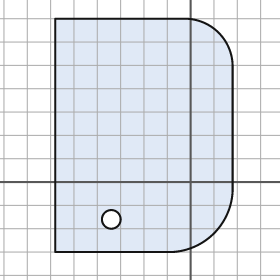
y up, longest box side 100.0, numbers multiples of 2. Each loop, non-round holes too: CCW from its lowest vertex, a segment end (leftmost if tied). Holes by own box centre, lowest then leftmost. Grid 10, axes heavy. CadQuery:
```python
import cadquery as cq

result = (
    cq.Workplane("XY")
    .moveTo(-58.0, -30.0)
    .lineTo(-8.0, -30.0)
    .threePointArc((10.0, -22.0), (18.0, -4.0))
    .lineTo(18.0, 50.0)
    .threePointArc((12.0, 64.0), (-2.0, 70.0))
    .lineTo(-58.0, 70.0)
    .close()
    .moveTo(-34.0, -16.0)
    .circle(4.0)
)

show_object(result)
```